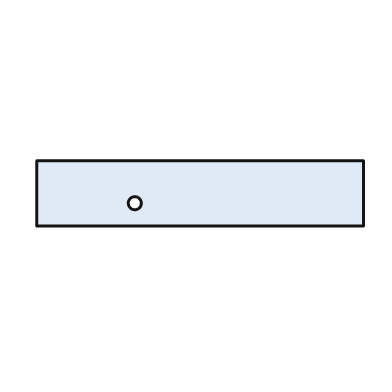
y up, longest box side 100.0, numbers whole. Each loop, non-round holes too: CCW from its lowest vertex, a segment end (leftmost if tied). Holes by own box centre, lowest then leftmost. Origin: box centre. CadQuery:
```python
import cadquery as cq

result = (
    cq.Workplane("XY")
    .moveTo(-50.0, -10.0)
    .lineTo(50.0, -10.0)
    .lineTo(50.0, 10.0)
    .lineTo(-50.0, 10.0)
    .close()
    .moveTo(-20.0, -3.0)
    .circle(2.0)
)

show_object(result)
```